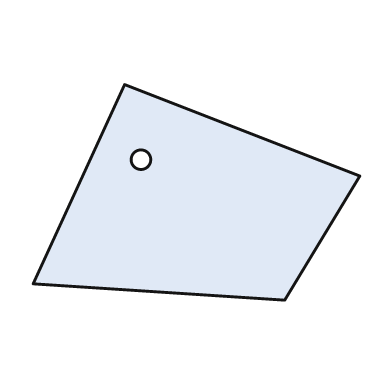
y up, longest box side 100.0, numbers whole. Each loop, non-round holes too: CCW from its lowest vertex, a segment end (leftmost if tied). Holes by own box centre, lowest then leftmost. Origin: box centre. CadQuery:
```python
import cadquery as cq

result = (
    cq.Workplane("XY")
    .moveTo(27.0, -33.0)
    .lineTo(50.0, 5.0)
    .lineTo(-22.0, 33.0)
    .lineTo(-50.0, -28.0)
    .close()
    .moveTo(-17.0, 10.0)
    .circle(3.0)
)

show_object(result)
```